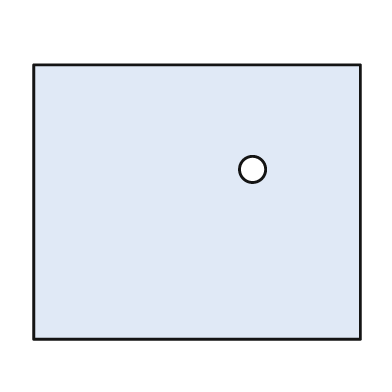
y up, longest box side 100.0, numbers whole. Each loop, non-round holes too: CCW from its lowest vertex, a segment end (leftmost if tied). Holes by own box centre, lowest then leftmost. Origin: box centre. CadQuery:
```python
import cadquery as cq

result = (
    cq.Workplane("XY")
    .moveTo(-50.0, -42.0)
    .lineTo(50.0, -42.0)
    .lineTo(50.0, 42.0)
    .lineTo(-50.0, 42.0)
    .close()
    .moveTo(17.0, 10.0)
    .circle(4.0)
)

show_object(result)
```